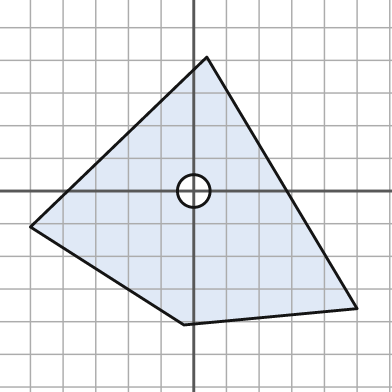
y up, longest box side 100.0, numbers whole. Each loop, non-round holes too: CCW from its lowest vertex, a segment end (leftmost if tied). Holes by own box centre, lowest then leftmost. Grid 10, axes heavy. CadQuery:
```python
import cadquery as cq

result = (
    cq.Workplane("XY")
    .moveTo(-3.0, -41.0)
    .lineTo(50.0, -36.0)
    .lineTo(4.0, 41.0)
    .lineTo(-50.0, -11.0)
    .close()
    .moveTo(0.0, 0.0)
    .circle(5.0)
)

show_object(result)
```